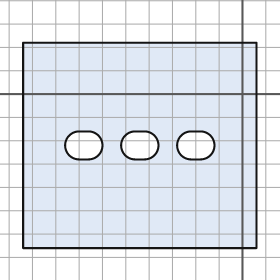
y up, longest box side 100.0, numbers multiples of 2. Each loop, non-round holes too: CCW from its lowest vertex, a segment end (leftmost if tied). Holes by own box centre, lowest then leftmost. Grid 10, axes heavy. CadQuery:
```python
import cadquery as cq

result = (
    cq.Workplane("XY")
    .moveTo(-94.0, -66.0)
    .lineTo(6.0, -66.0)
    .lineTo(6.0, 22.0)
    .lineTo(-94.0, 22.0)
    .close()
    .moveTo(-70.0, -28.0)
    .lineTo(-66.0, -28.0)
    .threePointArc((-60.0, -22.0), (-66.0, -16.0))
    .lineTo(-70.0, -16.0)
    .threePointArc((-76.0, -22.0), (-70.0, -28.0))
    .close()
    .moveTo(-46.0, -28.0)
    .lineTo(-42.0, -28.0)
    .threePointArc((-36.0, -22.0), (-42.0, -16.0))
    .lineTo(-46.0, -16.0)
    .threePointArc((-52.0, -22.0), (-46.0, -28.0))
    .close()
    .moveTo(-22.0, -28.0)
    .lineTo(-18.0, -28.0)
    .threePointArc((-12.0, -22.0), (-18.0, -16.0))
    .lineTo(-22.0, -16.0)
    .threePointArc((-28.0, -22.0), (-22.0, -28.0))
    .close()
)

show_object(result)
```